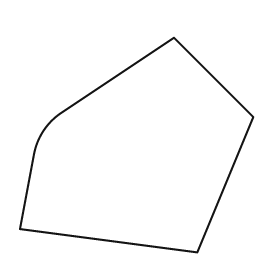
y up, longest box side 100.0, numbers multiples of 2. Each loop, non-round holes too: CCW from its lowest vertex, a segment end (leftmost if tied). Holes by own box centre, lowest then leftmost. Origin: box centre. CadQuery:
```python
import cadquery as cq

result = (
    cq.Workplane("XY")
    .moveTo(26.0, -46.0)
    .lineTo(50.0, 12.0)
    .lineTo(16.0, 46.0)
    .lineTo(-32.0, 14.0)
    .threePointArc((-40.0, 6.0), (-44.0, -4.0))
    .lineTo(-50.0, -36.0)
    .close()
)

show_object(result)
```